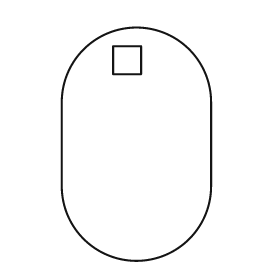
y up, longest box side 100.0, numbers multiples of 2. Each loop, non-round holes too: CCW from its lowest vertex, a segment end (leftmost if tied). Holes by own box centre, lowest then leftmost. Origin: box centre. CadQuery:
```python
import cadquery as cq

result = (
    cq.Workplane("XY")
    .moveTo(-32.0, -18.0)
    .threePointArc((0.0, -50.0), (32.0, -18.0))
    .lineTo(32.0, 18.0)
    .threePointArc((0.0, 50.0), (-32.0, 18.0))
    .close()
    .moveTo(-10.0, 30.0)
    .lineTo(2.0, 30.0)
    .lineTo(2.0, 42.0)
    .lineTo(-10.0, 42.0)
    .close()
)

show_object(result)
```